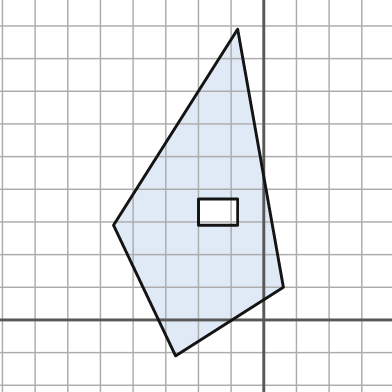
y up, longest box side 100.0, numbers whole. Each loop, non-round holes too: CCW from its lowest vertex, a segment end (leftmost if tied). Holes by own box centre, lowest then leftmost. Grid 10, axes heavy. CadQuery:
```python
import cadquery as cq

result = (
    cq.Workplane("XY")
    .moveTo(-27.0, -11.0)
    .lineTo(6.0, 10.0)
    .lineTo(-8.0, 89.0)
    .lineTo(-46.0, 29.0)
    .close()
    .moveTo(-20.0, 29.0)
    .lineTo(-8.0, 29.0)
    .lineTo(-8.0, 37.0)
    .lineTo(-20.0, 37.0)
    .close()
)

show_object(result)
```